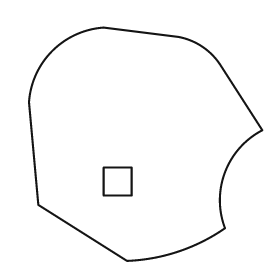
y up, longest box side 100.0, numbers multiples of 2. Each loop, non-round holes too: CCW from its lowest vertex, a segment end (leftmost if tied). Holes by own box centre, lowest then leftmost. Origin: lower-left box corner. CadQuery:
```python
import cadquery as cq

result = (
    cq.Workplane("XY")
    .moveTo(42.0, 0.0)
    .threePointArc((64.0, 4.0), (84.0, 14.0))
    .threePointArc((84.0, 38.0), (100.0, 56.0))
    .lineTo(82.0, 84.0)
    .threePointArc((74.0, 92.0), (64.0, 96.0))
    .lineTo(32.0, 100.0)
    .threePointArc((10.0, 90.0), (0.0, 68.0))
    .lineTo(4.0, 24.0)
    .close()
    .moveTo(32.0, 28.0)
    .lineTo(44.0, 28.0)
    .lineTo(44.0, 40.0)
    .lineTo(32.0, 40.0)
    .close()
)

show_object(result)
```